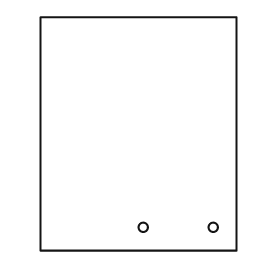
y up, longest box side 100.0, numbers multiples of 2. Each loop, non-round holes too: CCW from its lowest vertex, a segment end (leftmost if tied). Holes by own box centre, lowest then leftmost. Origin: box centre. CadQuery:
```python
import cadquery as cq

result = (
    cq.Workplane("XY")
    .moveTo(-42.0, -50.0)
    .lineTo(42.0, -50.0)
    .lineTo(42.0, 50.0)
    .lineTo(-42.0, 50.0)
    .close()
    .moveTo(2.0, -40.0)
    .circle(2.0)
    .moveTo(32.0, -40.0)
    .circle(2.0)
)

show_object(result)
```